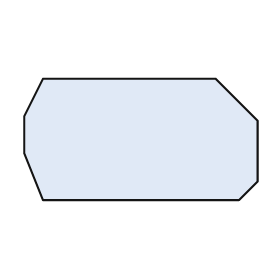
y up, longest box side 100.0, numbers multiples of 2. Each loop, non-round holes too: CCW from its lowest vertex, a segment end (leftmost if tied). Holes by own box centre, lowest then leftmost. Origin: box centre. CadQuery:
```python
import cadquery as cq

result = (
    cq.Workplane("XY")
    .moveTo(-42.0, -26.0)
    .lineTo(42.0, -26.0)
    .lineTo(50.0, -18.0)
    .lineTo(50.0, 8.0)
    .lineTo(32.0, 26.0)
    .lineTo(-42.0, 26.0)
    .lineTo(-50.0, 10.0)
    .lineTo(-50.0, -6.0)
    .close()
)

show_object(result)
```